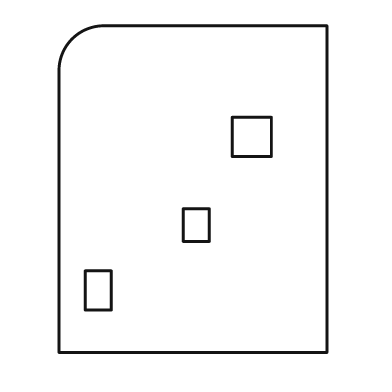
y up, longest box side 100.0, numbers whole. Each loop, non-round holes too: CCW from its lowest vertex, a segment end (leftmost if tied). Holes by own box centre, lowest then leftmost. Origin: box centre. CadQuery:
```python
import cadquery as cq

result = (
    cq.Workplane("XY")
    .moveTo(-41.0, -50.0)
    .lineTo(41.0, -50.0)
    .lineTo(41.0, 50.0)
    .lineTo(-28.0, 50.0)
    .threePointArc((-37.0, 46.0), (-41.0, 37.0))
    .close()
    .moveTo(-33.0, -37.0)
    .lineTo(-25.0, -37.0)
    .lineTo(-25.0, -25.0)
    .lineTo(-33.0, -25.0)
    .close()
    .moveTo(-3.0, -16.0)
    .lineTo(5.0, -16.0)
    .lineTo(5.0, -6.0)
    .lineTo(-3.0, -6.0)
    .close()
    .moveTo(12.0, 10.0)
    .lineTo(24.0, 10.0)
    .lineTo(24.0, 22.0)
    .lineTo(12.0, 22.0)
    .close()
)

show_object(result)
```